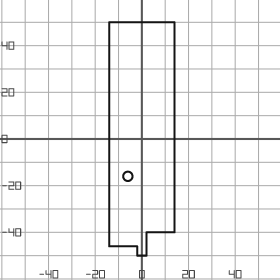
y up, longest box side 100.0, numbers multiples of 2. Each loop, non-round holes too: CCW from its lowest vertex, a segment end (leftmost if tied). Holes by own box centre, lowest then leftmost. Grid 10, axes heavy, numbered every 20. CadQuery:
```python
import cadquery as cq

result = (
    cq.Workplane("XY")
    .moveTo(-2.0, -50.0)
    .lineTo(2.0, -50.0)
    .lineTo(2.0, -40.0)
    .lineTo(14.0, -40.0)
    .lineTo(14.0, 50.0)
    .lineTo(-14.0, 50.0)
    .lineTo(-14.0, -46.0)
    .lineTo(-2.0, -46.0)
    .close()
    .moveTo(-6.0, -16.0)
    .circle(2.0)
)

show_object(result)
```